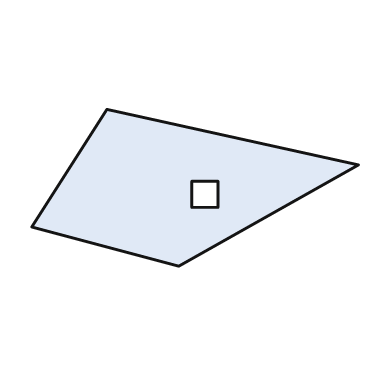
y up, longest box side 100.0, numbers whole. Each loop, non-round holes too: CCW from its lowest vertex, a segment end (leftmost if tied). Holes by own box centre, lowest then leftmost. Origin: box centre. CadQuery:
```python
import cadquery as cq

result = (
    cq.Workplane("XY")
    .moveTo(-5.0, -24.0)
    .lineTo(50.0, 7.0)
    .lineTo(-27.0, 24.0)
    .lineTo(-50.0, -12.0)
    .close()
    .moveTo(-1.0, -6.0)
    .lineTo(7.0, -6.0)
    .lineTo(7.0, 2.0)
    .lineTo(-1.0, 2.0)
    .close()
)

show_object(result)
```